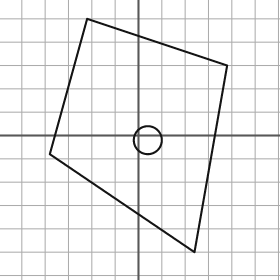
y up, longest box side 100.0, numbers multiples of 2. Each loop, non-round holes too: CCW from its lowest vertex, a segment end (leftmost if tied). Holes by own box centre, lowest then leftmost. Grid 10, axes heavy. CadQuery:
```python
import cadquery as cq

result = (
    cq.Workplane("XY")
    .moveTo(24.0, -50.0)
    .lineTo(38.0, 30.0)
    .lineTo(-22.0, 50.0)
    .lineTo(-38.0, -8.0)
    .close()
    .moveTo(4.0, -2.0)
    .circle(6.0)
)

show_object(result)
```